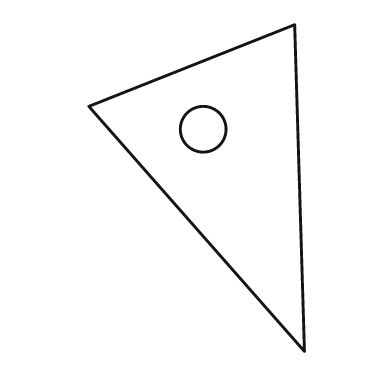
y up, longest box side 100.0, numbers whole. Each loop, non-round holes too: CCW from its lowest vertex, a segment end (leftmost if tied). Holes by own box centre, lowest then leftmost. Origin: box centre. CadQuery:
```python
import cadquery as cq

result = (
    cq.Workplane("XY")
    .moveTo(33.0, -50.0)
    .lineTo(30.0, 50.0)
    .lineTo(-33.0, 25.0)
    .close()
    .moveTo(2.0, 18.0)
    .circle(7.0)
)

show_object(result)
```